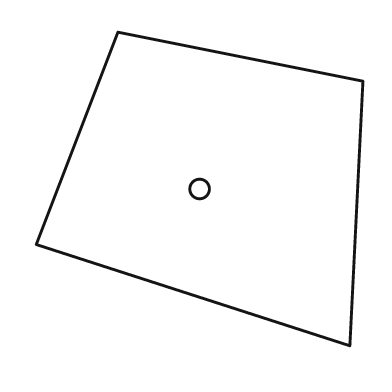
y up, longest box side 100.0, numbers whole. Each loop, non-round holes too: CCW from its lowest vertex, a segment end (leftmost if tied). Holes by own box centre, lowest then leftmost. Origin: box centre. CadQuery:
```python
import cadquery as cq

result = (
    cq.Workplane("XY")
    .moveTo(46.0, -48.0)
    .lineTo(50.0, 33.0)
    .lineTo(-25.0, 48.0)
    .lineTo(-50.0, -17.0)
    .close()
    .moveTo(0.0, 0.0)
    .circle(3.0)
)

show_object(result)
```